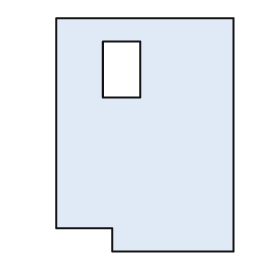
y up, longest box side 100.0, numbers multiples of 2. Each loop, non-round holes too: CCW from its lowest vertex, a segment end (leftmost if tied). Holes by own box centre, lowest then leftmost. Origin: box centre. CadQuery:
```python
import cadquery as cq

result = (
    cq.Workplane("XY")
    .moveTo(-14.0, -50.0)
    .lineTo(38.0, -50.0)
    .lineTo(38.0, 50.0)
    .lineTo(-38.0, 50.0)
    .lineTo(-38.0, -40.0)
    .lineTo(-14.0, -40.0)
    .close()
    .moveTo(-18.0, 16.0)
    .lineTo(-2.0, 16.0)
    .lineTo(-2.0, 40.0)
    .lineTo(-18.0, 40.0)
    .close()
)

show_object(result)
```